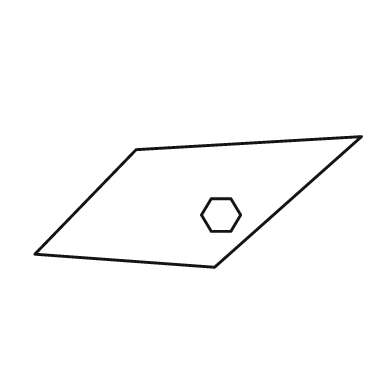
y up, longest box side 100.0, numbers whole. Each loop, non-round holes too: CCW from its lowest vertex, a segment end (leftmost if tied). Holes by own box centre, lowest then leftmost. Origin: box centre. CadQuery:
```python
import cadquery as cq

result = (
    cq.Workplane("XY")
    .moveTo(5.0, -20.0)
    .lineTo(50.0, 20.0)
    .lineTo(-19.0, 16.0)
    .lineTo(-50.0, -16.0)
    .close()
    .moveTo(4.0, -9.0)
    .lineTo(10.0, -9.0)
    .lineTo(13.0, -4.0)
    .lineTo(10.0, 1.0)
    .lineTo(4.0, 1.0)
    .lineTo(1.0, -4.0)
    .close()
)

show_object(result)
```